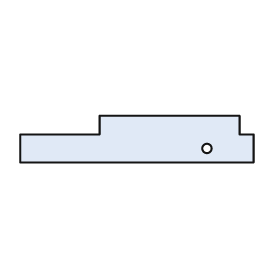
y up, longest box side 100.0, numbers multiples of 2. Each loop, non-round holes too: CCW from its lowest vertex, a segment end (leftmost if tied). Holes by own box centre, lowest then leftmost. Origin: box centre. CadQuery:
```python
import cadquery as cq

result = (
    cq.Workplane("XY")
    .moveTo(-50.0, -10.0)
    .lineTo(50.0, -10.0)
    .lineTo(50.0, 2.0)
    .lineTo(44.0, 2.0)
    .lineTo(44.0, 10.0)
    .lineTo(-16.0, 10.0)
    .lineTo(-16.0, 2.0)
    .lineTo(-50.0, 2.0)
    .close()
    .moveTo(30.0, -4.0)
    .circle(2.0)
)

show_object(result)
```